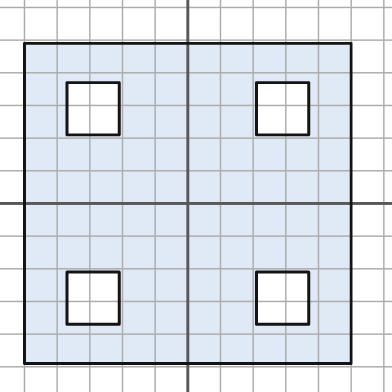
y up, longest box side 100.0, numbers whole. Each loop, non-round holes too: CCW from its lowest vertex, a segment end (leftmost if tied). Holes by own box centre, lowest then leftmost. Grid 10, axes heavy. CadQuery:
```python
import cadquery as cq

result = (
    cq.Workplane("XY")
    .moveTo(-50.0, -49.0)
    .lineTo(50.0, -49.0)
    .lineTo(50.0, 49.0)
    .lineTo(-50.0, 49.0)
    .close()
    .moveTo(-37.0, -37.0)
    .lineTo(-21.0, -37.0)
    .lineTo(-21.0, -21.0)
    .lineTo(-37.0, -21.0)
    .close()
    .moveTo(21.0, -37.0)
    .lineTo(37.0, -37.0)
    .lineTo(37.0, -21.0)
    .lineTo(21.0, -21.0)
    .close()
    .moveTo(-37.0, 21.0)
    .lineTo(-21.0, 21.0)
    .lineTo(-21.0, 37.0)
    .lineTo(-37.0, 37.0)
    .close()
    .moveTo(21.0, 21.0)
    .lineTo(37.0, 21.0)
    .lineTo(37.0, 37.0)
    .lineTo(21.0, 37.0)
    .close()
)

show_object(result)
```